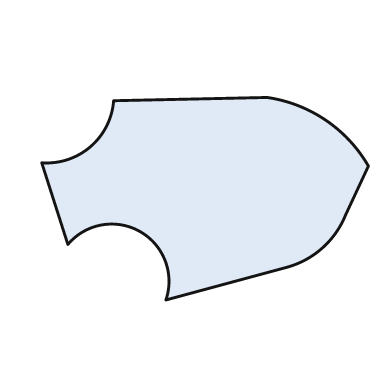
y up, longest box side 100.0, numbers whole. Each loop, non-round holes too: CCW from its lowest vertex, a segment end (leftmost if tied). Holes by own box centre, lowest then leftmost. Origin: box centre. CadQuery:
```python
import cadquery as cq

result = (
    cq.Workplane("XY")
    .moveTo(-12.0, -31.0)
    .lineTo(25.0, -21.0)
    .threePointArc((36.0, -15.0), (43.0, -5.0))
    .lineTo(50.0, 10.0)
    .threePointArc((37.0, 24.0), (19.0, 31.0))
    .lineTo(-28.0, 30.0)
    .threePointArc((-35.0, 16.0), (-50.0, 11.0))
    .lineTo(-42.0, -14.0)
    .threePointArc((-20.0, -10.0), (-12.0, -31.0))
    .close()
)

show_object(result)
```